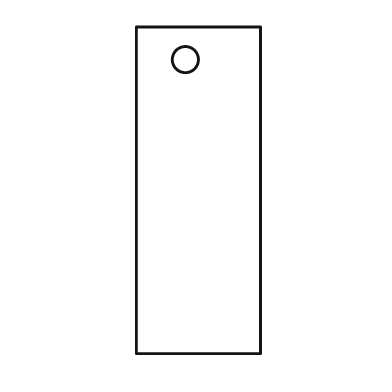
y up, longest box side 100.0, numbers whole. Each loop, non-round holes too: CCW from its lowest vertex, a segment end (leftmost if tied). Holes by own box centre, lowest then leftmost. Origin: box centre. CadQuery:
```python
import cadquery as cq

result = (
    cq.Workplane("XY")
    .moveTo(-19.0, -50.0)
    .lineTo(19.0, -50.0)
    .lineTo(19.0, 50.0)
    .lineTo(-19.0, 50.0)
    .close()
    .moveTo(-4.0, 40.0)
    .circle(4.0)
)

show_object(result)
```